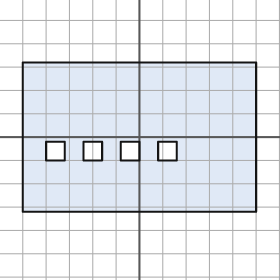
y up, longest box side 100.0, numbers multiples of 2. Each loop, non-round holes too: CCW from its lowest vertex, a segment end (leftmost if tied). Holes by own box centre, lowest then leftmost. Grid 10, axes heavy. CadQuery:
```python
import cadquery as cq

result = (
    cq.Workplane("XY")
    .moveTo(-50.0, -32.0)
    .lineTo(50.0, -32.0)
    .lineTo(50.0, 32.0)
    .lineTo(-50.0, 32.0)
    .close()
    .moveTo(-40.0, -10.0)
    .lineTo(-32.0, -10.0)
    .lineTo(-32.0, -2.0)
    .lineTo(-40.0, -2.0)
    .close()
    .moveTo(-24.0, -10.0)
    .lineTo(-16.0, -10.0)
    .lineTo(-16.0, -2.0)
    .lineTo(-24.0, -2.0)
    .close()
    .moveTo(-8.0, -10.0)
    .lineTo(0.0, -10.0)
    .lineTo(0.0, -2.0)
    .lineTo(-8.0, -2.0)
    .close()
    .moveTo(8.0, -10.0)
    .lineTo(16.0, -10.0)
    .lineTo(16.0, -2.0)
    .lineTo(8.0, -2.0)
    .close()
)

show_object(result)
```